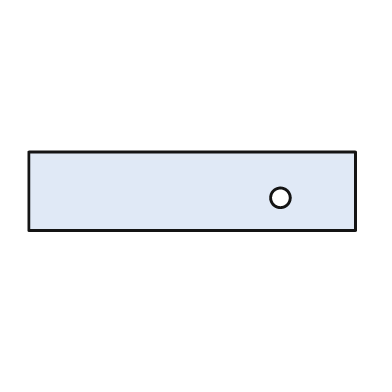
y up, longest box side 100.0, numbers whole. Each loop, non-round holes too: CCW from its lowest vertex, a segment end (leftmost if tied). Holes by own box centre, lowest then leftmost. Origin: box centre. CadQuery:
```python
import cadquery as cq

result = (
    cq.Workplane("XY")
    .moveTo(-50.0, -12.0)
    .lineTo(50.0, -12.0)
    .lineTo(50.0, 12.0)
    .lineTo(-50.0, 12.0)
    .close()
    .moveTo(27.0, -2.0)
    .circle(3.0)
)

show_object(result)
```